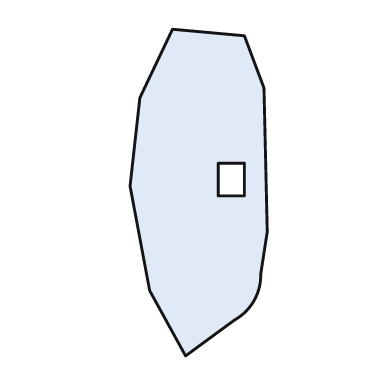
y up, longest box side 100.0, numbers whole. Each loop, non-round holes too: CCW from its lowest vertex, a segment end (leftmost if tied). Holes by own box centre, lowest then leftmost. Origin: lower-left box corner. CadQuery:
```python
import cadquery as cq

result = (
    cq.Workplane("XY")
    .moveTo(17.0, 0.0)
    .lineTo(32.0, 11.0)
    .threePointArc((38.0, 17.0), (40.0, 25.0))
    .lineTo(42.0, 38.0)
    .lineTo(41.0, 82.0)
    .lineTo(35.0, 98.0)
    .lineTo(13.0, 100.0)
    .lineTo(3.0, 79.0)
    .lineTo(0.0, 52.0)
    .lineTo(6.0, 20.0)
    .close()
    .moveTo(27.0, 49.0)
    .lineTo(35.0, 49.0)
    .lineTo(35.0, 59.0)
    .lineTo(27.0, 59.0)
    .close()
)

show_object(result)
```